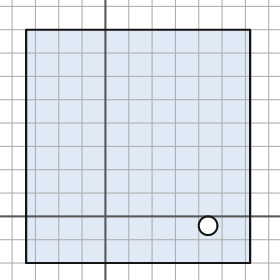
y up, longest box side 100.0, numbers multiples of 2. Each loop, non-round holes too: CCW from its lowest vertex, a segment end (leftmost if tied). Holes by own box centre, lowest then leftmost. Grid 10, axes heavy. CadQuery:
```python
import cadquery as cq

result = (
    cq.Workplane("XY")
    .moveTo(-34.0, -20.0)
    .lineTo(62.0, -20.0)
    .lineTo(62.0, 80.0)
    .lineTo(-34.0, 80.0)
    .close()
    .moveTo(44.0, -4.0)
    .circle(4.0)
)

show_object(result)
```